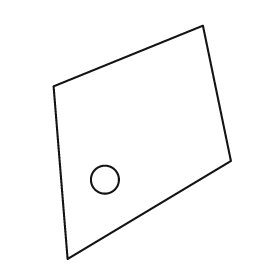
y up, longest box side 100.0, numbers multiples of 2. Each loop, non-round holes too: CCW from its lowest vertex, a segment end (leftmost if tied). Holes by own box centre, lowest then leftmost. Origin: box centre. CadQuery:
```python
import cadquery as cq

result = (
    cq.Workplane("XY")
    .moveTo(-32.0, -50.0)
    .lineTo(38.0, -8.0)
    .lineTo(26.0, 50.0)
    .lineTo(-38.0, 24.0)
    .close()
    .moveTo(-16.0, -16.0)
    .circle(6.0)
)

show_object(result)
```